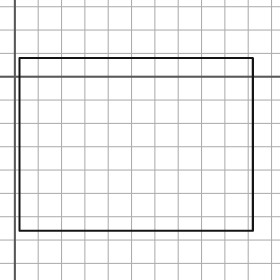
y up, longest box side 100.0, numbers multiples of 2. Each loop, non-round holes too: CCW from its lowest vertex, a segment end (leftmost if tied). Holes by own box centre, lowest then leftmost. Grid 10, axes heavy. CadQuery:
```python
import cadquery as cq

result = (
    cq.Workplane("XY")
    .moveTo(2.0, -66.0)
    .lineTo(102.0, -66.0)
    .lineTo(102.0, 8.0)
    .lineTo(2.0, 8.0)
    .close()
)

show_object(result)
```